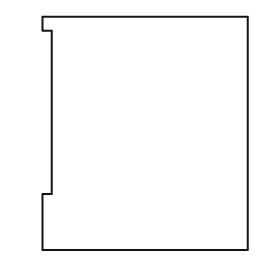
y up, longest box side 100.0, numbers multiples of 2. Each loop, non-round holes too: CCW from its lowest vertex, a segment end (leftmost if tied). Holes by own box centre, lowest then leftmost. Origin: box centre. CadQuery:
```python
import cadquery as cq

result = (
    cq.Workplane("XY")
    .moveTo(-44.0, -50.0)
    .lineTo(44.0, -50.0)
    .lineTo(44.0, 50.0)
    .lineTo(-44.0, 50.0)
    .lineTo(-44.0, 44.0)
    .lineTo(-40.0, 44.0)
    .lineTo(-40.0, -26.0)
    .lineTo(-44.0, -26.0)
    .close()
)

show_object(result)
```